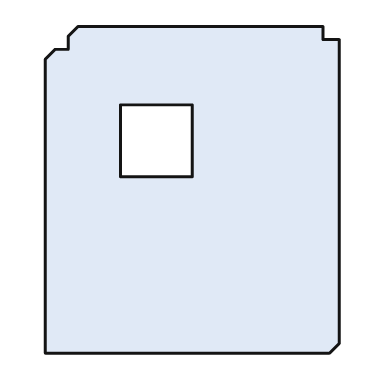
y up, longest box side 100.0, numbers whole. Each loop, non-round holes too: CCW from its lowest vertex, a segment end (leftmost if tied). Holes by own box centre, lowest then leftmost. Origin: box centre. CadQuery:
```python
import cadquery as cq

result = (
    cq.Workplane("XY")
    .moveTo(-45.0, -50.0)
    .lineTo(42.0, -50.0)
    .lineTo(45.0, -47.0)
    .lineTo(45.0, 46.0)
    .lineTo(40.0, 46.0)
    .lineTo(40.0, 50.0)
    .lineTo(-35.0, 50.0)
    .lineTo(-38.0, 47.0)
    .lineTo(-38.0, 43.0)
    .lineTo(-42.0, 43.0)
    .lineTo(-45.0, 40.0)
    .close()
    .moveTo(-22.0, 4.0)
    .lineTo(0.0, 4.0)
    .lineTo(0.0, 26.0)
    .lineTo(-22.0, 26.0)
    .close()
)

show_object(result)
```